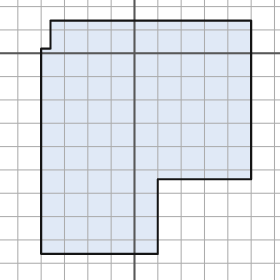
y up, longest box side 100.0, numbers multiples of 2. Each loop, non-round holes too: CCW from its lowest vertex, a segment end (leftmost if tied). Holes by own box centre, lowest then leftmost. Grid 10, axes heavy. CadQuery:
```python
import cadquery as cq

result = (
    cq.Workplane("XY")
    .moveTo(-40.0, -86.0)
    .lineTo(10.0, -86.0)
    .lineTo(10.0, -54.0)
    .lineTo(50.0, -54.0)
    .lineTo(50.0, 14.0)
    .lineTo(-36.0, 14.0)
    .lineTo(-36.0, 2.0)
    .lineTo(-40.0, 2.0)
    .close()
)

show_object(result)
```